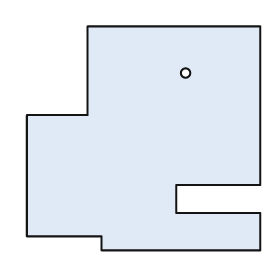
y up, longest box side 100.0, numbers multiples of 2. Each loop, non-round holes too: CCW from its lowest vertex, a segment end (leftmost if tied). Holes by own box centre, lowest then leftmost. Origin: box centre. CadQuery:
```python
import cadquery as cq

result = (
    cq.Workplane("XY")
    .moveTo(-18.0, -48.0)
    .lineTo(50.0, -48.0)
    .lineTo(50.0, -32.0)
    .lineTo(14.0, -32.0)
    .lineTo(14.0, -20.0)
    .lineTo(50.0, -20.0)
    .lineTo(50.0, 48.0)
    .lineTo(-24.0, 48.0)
    .lineTo(-24.0, 10.0)
    .lineTo(-50.0, 10.0)
    .lineTo(-50.0, -42.0)
    .lineTo(-18.0, -42.0)
    .close()
    .moveTo(18.0, 28.0)
    .circle(2.0)
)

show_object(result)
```